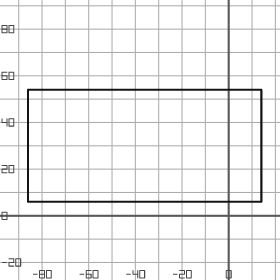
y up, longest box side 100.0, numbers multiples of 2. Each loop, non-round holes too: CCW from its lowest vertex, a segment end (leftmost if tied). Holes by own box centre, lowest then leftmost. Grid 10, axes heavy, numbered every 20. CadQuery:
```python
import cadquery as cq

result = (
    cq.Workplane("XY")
    .moveTo(-86.0, 6.0)
    .lineTo(14.0, 6.0)
    .lineTo(14.0, 54.0)
    .lineTo(-86.0, 54.0)
    .close()
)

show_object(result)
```